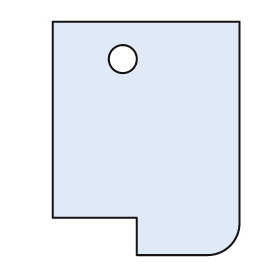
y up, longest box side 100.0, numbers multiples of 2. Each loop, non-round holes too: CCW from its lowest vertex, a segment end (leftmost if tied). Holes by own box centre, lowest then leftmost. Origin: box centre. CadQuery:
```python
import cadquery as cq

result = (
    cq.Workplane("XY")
    .moveTo(-4.0, -50.0)
    .lineTo(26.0, -50.0)
    .threePointArc((36.0, -46.0), (40.0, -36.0))
    .lineTo(40.0, 50.0)
    .lineTo(-40.0, 50.0)
    .lineTo(-40.0, -34.0)
    .lineTo(-4.0, -34.0)
    .close()
    .moveTo(-10.0, 34.0)
    .circle(6.0)
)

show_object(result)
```